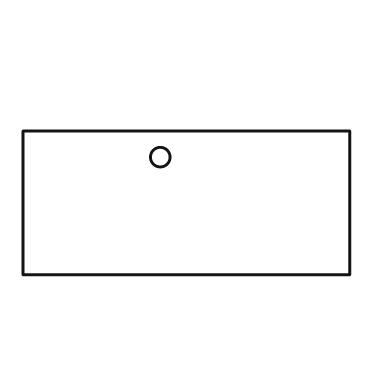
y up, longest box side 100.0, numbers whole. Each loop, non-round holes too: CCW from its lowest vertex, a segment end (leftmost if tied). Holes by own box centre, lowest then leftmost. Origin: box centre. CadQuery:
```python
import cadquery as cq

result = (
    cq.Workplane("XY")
    .moveTo(-50.0, -22.0)
    .lineTo(50.0, -22.0)
    .lineTo(50.0, 22.0)
    .lineTo(-50.0, 22.0)
    .close()
    .moveTo(-8.0, 14.0)
    .circle(3.0)
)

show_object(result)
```